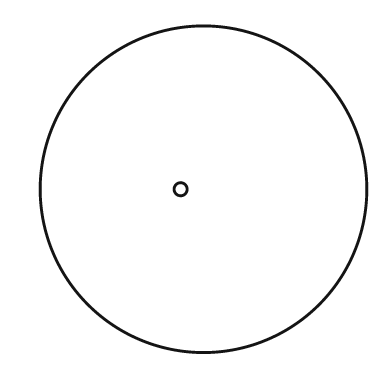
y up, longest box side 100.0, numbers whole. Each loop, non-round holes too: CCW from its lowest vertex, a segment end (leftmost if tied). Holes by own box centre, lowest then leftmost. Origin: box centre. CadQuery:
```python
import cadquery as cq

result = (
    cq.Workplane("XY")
    .moveTo(0.0, 0.0)
    .circle(50.0)
    .moveTo(-7.0, 0.0)
    .circle(2.0)
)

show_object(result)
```